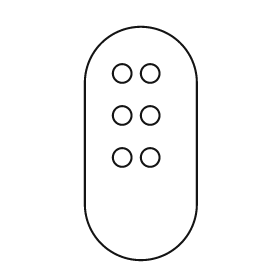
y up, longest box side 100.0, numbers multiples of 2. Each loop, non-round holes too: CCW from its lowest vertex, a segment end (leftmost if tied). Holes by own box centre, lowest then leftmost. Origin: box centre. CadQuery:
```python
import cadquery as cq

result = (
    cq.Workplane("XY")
    .moveTo(-24.0, -26.0)
    .threePointArc((0.0, -50.0), (24.0, -26.0))
    .lineTo(24.0, 26.0)
    .threePointArc((0.0, 50.0), (-24.0, 26.0))
    .close()
    .moveTo(-8.0, -6.0)
    .circle(4.0)
    .moveTo(4.0, -6.0)
    .circle(4.0)
    .moveTo(-8.0, 12.0)
    .circle(4.0)
    .moveTo(4.0, 12.0)
    .circle(4.0)
    .moveTo(-8.0, 30.0)
    .circle(4.0)
    .moveTo(4.0, 30.0)
    .circle(4.0)
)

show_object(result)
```